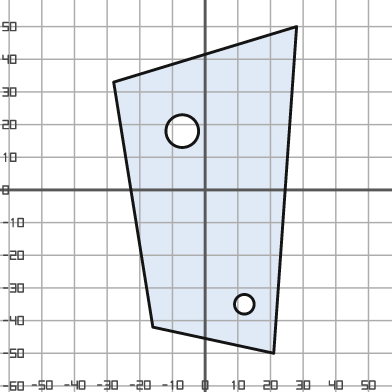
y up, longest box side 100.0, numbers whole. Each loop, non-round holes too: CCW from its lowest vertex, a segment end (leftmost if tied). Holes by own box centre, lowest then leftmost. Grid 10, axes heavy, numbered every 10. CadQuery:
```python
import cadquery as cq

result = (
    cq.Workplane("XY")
    .moveTo(21.0, -50.0)
    .lineTo(28.0, 50.0)
    .lineTo(-28.0, 33.0)
    .lineTo(-16.0, -42.0)
    .close()
    .moveTo(12.0, -35.0)
    .circle(3.0)
    .moveTo(-7.0, 18.0)
    .circle(5.0)
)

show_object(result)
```